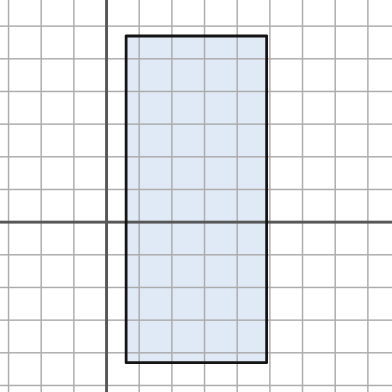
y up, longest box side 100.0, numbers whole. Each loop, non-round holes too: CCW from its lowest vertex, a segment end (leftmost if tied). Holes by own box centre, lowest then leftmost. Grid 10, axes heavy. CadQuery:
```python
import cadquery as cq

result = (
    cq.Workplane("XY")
    .moveTo(6.0, -43.0)
    .lineTo(49.0, -43.0)
    .lineTo(49.0, 57.0)
    .lineTo(6.0, 57.0)
    .close()
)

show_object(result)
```